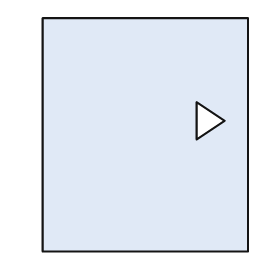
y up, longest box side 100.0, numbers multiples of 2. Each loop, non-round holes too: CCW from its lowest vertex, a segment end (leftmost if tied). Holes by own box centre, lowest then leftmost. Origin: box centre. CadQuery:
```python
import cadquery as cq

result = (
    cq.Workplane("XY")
    .moveTo(-44.0, -50.0)
    .lineTo(44.0, -50.0)
    .lineTo(44.0, 50.0)
    .lineTo(-44.0, 50.0)
    .close()
    .moveTo(22.0, -2.0)
    .lineTo(34.0, 6.0)
    .lineTo(22.0, 14.0)
    .close()
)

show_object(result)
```